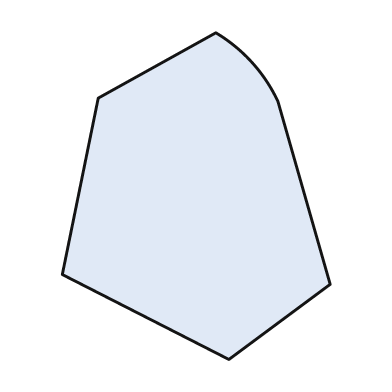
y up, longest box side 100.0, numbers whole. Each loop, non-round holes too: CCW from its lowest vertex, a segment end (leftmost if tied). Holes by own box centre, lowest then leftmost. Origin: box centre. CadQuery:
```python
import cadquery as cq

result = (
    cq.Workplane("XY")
    .moveTo(10.0, -50.0)
    .lineTo(41.0, -27.0)
    .lineTo(25.0, 29.0)
    .threePointArc((17.0, 41.0), (6.0, 50.0))
    .lineTo(-30.0, 30.0)
    .lineTo(-41.0, -24.0)
    .close()
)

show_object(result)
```